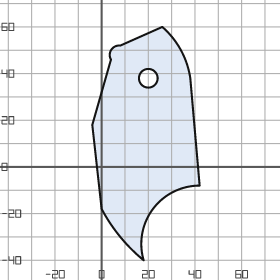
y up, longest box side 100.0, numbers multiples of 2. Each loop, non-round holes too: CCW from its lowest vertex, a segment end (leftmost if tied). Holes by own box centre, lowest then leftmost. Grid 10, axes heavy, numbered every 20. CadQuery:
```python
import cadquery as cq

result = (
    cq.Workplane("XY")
    .moveTo(18.0, -40.0)
    .threePointArc((22.0, -18.0), (42.0, -8.0))
    .lineTo(38.0, 38.0)
    .threePointArc((34.0, 50.0), (26.0, 60.0))
    .lineTo(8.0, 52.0)
    .threePointArc((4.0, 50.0), (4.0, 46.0))
    .lineTo(-4.0, 18.0)
    .lineTo(0.0, -18.0)
    .threePointArc((8.0, -30.0), (18.0, -40.0))
    .close()
    .moveTo(20.0, 38.0)
    .circle(4.0)
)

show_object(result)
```